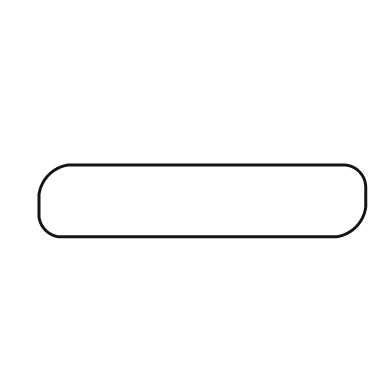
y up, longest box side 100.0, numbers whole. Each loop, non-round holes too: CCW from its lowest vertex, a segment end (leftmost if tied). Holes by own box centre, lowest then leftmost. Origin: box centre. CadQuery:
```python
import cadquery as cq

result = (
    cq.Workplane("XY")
    .moveTo(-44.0, -11.0)
    .lineTo(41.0, -11.0)
    .threePointArc((47.0, -8.0), (50.0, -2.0))
    .lineTo(50.0, 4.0)
    .threePointArc((48.0, 9.0), (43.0, 11.0))
    .lineTo(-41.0, 11.0)
    .threePointArc((-47.0, 8.0), (-50.0, 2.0))
    .lineTo(-50.0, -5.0)
    .threePointArc((-48.0, -9.0), (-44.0, -11.0))
    .close()
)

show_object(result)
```